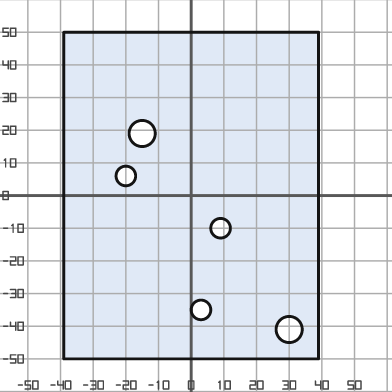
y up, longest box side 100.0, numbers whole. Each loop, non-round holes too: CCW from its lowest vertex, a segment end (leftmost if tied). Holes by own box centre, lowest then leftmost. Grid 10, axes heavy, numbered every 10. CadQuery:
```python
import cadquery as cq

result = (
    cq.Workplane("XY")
    .moveTo(-39.0, -50.0)
    .lineTo(39.0, -50.0)
    .lineTo(39.0, 50.0)
    .lineTo(-39.0, 50.0)
    .close()
    .moveTo(30.0, -41.0)
    .circle(4.0)
    .moveTo(3.0, -35.0)
    .circle(3.0)
    .moveTo(9.0, -10.0)
    .circle(3.0)
    .moveTo(-20.0, 6.0)
    .circle(3.0)
    .moveTo(-15.0, 19.0)
    .circle(4.0)
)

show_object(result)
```